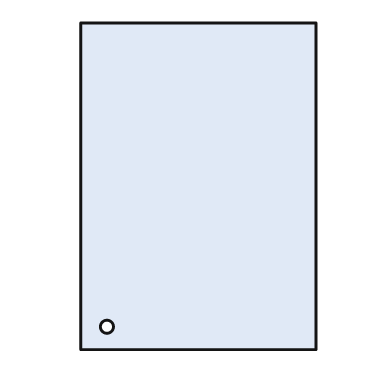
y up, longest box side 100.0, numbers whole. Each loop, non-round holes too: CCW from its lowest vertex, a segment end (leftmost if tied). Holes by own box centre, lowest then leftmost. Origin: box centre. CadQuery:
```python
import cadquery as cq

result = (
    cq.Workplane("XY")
    .moveTo(-36.0, -50.0)
    .lineTo(36.0, -50.0)
    .lineTo(36.0, 50.0)
    .lineTo(-36.0, 50.0)
    .close()
    .moveTo(-28.0, -43.0)
    .circle(2.0)
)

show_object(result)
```